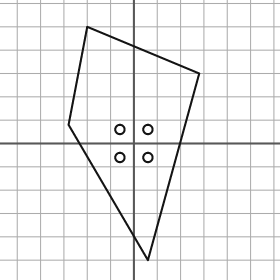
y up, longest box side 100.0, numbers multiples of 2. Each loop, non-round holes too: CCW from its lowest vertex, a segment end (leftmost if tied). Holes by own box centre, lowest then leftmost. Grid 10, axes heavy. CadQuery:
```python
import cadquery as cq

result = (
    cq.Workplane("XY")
    .moveTo(6.0, -50.0)
    .lineTo(28.0, 30.0)
    .lineTo(-20.0, 50.0)
    .lineTo(-28.0, 8.0)
    .close()
    .moveTo(-6.0, -6.0)
    .circle(2.0)
    .moveTo(6.0, -6.0)
    .circle(2.0)
    .moveTo(-6.0, 6.0)
    .circle(2.0)
    .moveTo(6.0, 6.0)
    .circle(2.0)
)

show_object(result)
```